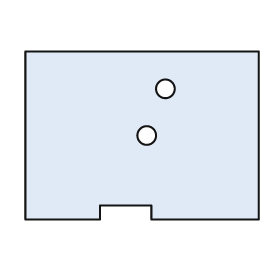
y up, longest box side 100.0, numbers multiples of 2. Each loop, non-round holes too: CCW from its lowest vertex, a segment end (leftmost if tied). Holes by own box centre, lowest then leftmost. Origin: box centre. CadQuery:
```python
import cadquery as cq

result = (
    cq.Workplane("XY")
    .moveTo(-50.0, -36.0)
    .lineTo(-18.0, -36.0)
    .lineTo(-18.0, -30.0)
    .lineTo(4.0, -30.0)
    .lineTo(4.0, -36.0)
    .lineTo(50.0, -36.0)
    .lineTo(50.0, 36.0)
    .lineTo(-50.0, 36.0)
    .close()
    .moveTo(2.0, 0.0)
    .circle(4.0)
    .moveTo(10.0, 20.0)
    .circle(4.0)
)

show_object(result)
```